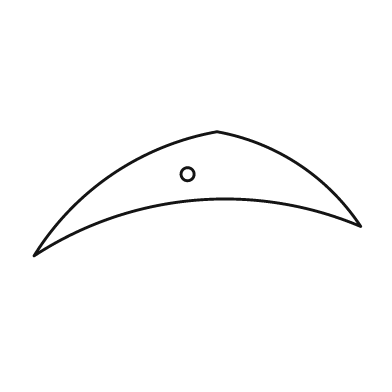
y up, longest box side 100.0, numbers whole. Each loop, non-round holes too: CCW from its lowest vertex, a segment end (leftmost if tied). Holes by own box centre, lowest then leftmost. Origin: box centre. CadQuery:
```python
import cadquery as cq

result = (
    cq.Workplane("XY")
    .moveTo(-50.0, -19.0)
    .threePointArc((-1.0, -2.0), (50.0, -10.0))
    .threePointArc((31.0, 9.0), (6.0, 19.0))
    .threePointArc((-26.0, 6.0), (-50.0, -19.0))
    .close()
    .moveTo(-3.0, 6.0)
    .circle(2.0)
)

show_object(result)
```